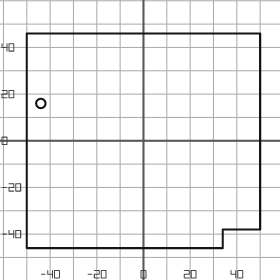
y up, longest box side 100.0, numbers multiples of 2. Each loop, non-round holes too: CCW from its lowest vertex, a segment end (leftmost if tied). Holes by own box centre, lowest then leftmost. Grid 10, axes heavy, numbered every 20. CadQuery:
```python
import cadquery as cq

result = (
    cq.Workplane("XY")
    .moveTo(-50.0, -46.0)
    .lineTo(34.0, -46.0)
    .lineTo(34.0, -38.0)
    .lineTo(50.0, -38.0)
    .lineTo(50.0, 46.0)
    .lineTo(-50.0, 46.0)
    .close()
    .moveTo(-44.0, 16.0)
    .circle(2.0)
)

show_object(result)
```